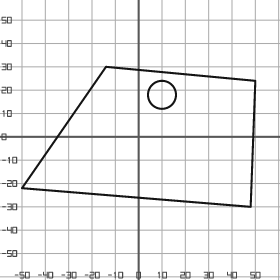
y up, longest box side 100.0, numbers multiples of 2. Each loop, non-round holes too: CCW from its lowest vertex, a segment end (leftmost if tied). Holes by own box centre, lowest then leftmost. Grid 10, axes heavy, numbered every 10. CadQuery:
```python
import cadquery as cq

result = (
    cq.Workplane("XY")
    .moveTo(48.0, -30.0)
    .lineTo(50.0, 24.0)
    .lineTo(-14.0, 30.0)
    .lineTo(-50.0, -22.0)
    .close()
    .moveTo(10.0, 18.0)
    .circle(6.0)
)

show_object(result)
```